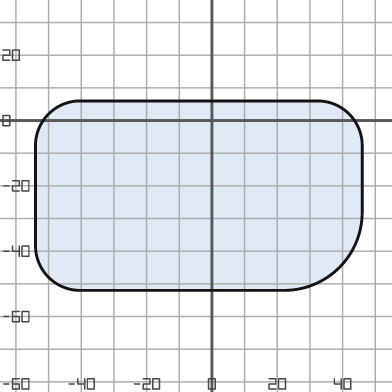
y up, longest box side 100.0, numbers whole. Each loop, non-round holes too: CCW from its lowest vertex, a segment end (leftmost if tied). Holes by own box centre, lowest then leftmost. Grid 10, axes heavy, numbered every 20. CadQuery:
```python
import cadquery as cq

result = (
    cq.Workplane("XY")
    .moveTo(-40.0, -52.0)
    .lineTo(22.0, -52.0)
    .threePointArc((39.0, -45.0), (46.0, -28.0))
    .lineTo(46.0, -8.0)
    .threePointArc((42.0, 2.0), (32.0, 6.0))
    .lineTo(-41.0, 6.0)
    .threePointArc((-50.0, 2.0), (-54.0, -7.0))
    .lineTo(-54.0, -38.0)
    .threePointArc((-50.0, -48.0), (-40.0, -52.0))
    .close()
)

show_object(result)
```